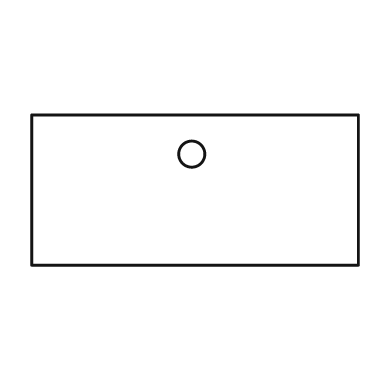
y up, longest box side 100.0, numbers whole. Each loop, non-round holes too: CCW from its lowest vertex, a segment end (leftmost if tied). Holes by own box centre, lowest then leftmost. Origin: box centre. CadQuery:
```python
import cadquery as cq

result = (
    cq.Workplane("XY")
    .moveTo(-50.0, -23.0)
    .lineTo(50.0, -23.0)
    .lineTo(50.0, 23.0)
    .lineTo(-50.0, 23.0)
    .close()
    .moveTo(-1.0, 11.0)
    .circle(4.0)
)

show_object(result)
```